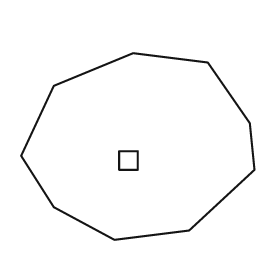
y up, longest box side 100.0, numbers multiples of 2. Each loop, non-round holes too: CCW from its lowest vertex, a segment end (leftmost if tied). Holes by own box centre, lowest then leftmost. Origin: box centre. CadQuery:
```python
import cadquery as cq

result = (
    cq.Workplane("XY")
    .moveTo(-10.0, -40.0)
    .lineTo(22.0, -36.0)
    .lineTo(50.0, -10.0)
    .lineTo(48.0, 10.0)
    .lineTo(30.0, 36.0)
    .lineTo(-2.0, 40.0)
    .lineTo(-36.0, 26.0)
    .lineTo(-50.0, -4.0)
    .lineTo(-36.0, -26.0)
    .close()
    .moveTo(-8.0, -10.0)
    .lineTo(0.0, -10.0)
    .lineTo(0.0, -2.0)
    .lineTo(-8.0, -2.0)
    .close()
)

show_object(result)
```